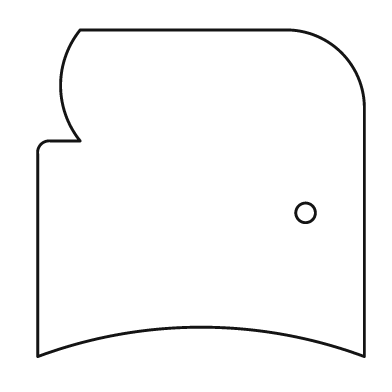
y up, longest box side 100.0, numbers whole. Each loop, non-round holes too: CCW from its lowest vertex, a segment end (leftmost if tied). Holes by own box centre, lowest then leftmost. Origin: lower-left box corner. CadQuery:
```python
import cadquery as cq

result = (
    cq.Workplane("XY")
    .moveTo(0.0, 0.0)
    .threePointArc((50.0, 9.0), (100.0, 0.0))
    .lineTo(100.0, 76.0)
    .threePointArc((93.0, 93.0), (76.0, 100.0))
    .lineTo(13.0, 100.0)
    .threePointArc((7.0, 83.0), (13.0, 66.0))
    .lineTo(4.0, 66.0)
    .threePointArc((1.0, 65.0), (0.0, 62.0))
    .close()
    .moveTo(82.0, 44.0)
    .circle(3.0)
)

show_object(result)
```